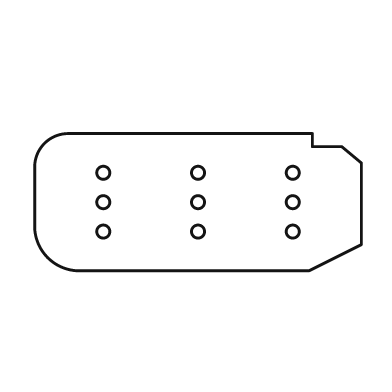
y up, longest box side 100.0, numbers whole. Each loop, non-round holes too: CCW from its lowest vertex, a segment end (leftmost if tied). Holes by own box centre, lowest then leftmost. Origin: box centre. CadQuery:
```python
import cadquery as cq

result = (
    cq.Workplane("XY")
    .moveTo(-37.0, -21.0)
    .lineTo(34.0, -21.0)
    .lineTo(50.0, -13.0)
    .lineTo(50.0, 12.0)
    .lineTo(44.0, 17.0)
    .lineTo(35.0, 17.0)
    .lineTo(35.0, 21.0)
    .lineTo(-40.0, 21.0)
    .threePointArc((-47.0, 18.0), (-50.0, 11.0))
    .lineTo(-50.0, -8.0)
    .threePointArc((-46.0, -17.0), (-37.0, -21.0))
    .close()
    .moveTo(-29.0, -9.0)
    .circle(2.0)
    .moveTo(0.0, -9.0)
    .circle(2.0)
    .moveTo(29.0, -9.0)
    .circle(2.0)
    .moveTo(-29.0, 0.0)
    .circle(2.0)
    .moveTo(0.0, 0.0)
    .circle(2.0)
    .moveTo(29.0, 0.0)
    .circle(2.0)
    .moveTo(-29.0, 9.0)
    .circle(2.0)
    .moveTo(0.0, 9.0)
    .circle(2.0)
    .moveTo(29.0, 9.0)
    .circle(2.0)
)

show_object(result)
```